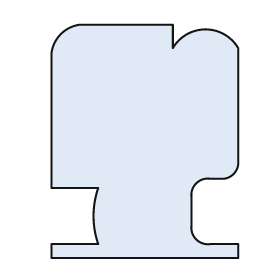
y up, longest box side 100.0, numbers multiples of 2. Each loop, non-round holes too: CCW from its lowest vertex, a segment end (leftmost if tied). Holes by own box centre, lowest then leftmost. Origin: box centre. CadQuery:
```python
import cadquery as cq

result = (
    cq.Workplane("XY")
    .moveTo(-40.0, -50.0)
    .lineTo(40.0, -50.0)
    .lineTo(40.0, -44.0)
    .lineTo(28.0, -44.0)
    .threePointArc((22.0, -42.0), (20.0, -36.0))
    .lineTo(20.0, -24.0)
    .threePointArc((22.0, -18.0), (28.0, -16.0))
    .lineTo(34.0, -16.0)
    .threePointArc((38.0, -14.0), (40.0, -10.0))
    .lineTo(40.0, 40.0)
    .threePointArc((26.0, 48.0), (12.0, 40.0))
    .lineTo(12.0, 50.0)
    .lineTo(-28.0, 50.0)
    .threePointArc((-36.0, 46.0), (-40.0, 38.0))
    .lineTo(-40.0, -20.0)
    .lineTo(-20.0, -20.0)
    .threePointArc((-22.0, -32.0), (-20.0, -44.0))
    .lineTo(-40.0, -44.0)
    .close()
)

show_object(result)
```